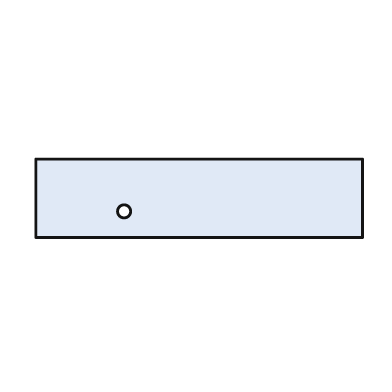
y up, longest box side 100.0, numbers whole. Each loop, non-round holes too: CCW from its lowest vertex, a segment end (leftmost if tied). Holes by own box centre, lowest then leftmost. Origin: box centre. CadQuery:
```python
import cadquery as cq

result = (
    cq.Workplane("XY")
    .moveTo(-50.0, -12.0)
    .lineTo(50.0, -12.0)
    .lineTo(50.0, 12.0)
    .lineTo(-50.0, 12.0)
    .close()
    .moveTo(-23.0, -4.0)
    .circle(2.0)
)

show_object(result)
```